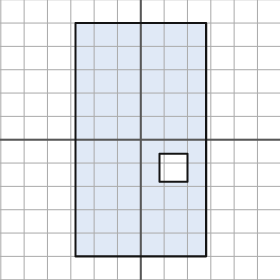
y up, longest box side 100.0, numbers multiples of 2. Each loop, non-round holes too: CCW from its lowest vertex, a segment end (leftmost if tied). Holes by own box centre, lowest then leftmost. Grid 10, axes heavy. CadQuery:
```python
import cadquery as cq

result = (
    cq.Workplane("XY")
    .moveTo(-28.0, -50.0)
    .lineTo(28.0, -50.0)
    .lineTo(28.0, 50.0)
    .lineTo(-28.0, 50.0)
    .close()
    .moveTo(8.0, -18.0)
    .lineTo(20.0, -18.0)
    .lineTo(20.0, -6.0)
    .lineTo(8.0, -6.0)
    .close()
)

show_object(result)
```